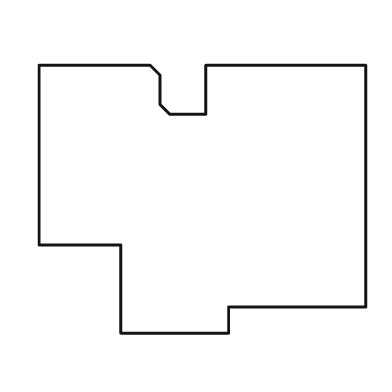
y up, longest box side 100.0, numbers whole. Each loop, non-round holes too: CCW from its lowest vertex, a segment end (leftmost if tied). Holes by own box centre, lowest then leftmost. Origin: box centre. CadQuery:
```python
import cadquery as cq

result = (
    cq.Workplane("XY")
    .moveTo(-25.0, -41.0)
    .lineTo(8.0, -41.0)
    .lineTo(8.0, -33.0)
    .lineTo(50.0, -33.0)
    .lineTo(50.0, 41.0)
    .lineTo(1.0, 41.0)
    .lineTo(1.0, 26.0)
    .lineTo(-10.0, 26.0)
    .lineTo(-13.0, 29.0)
    .lineTo(-13.0, 38.0)
    .lineTo(-16.0, 41.0)
    .lineTo(-50.0, 41.0)
    .lineTo(-50.0, -14.0)
    .lineTo(-25.0, -14.0)
    .close()
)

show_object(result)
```